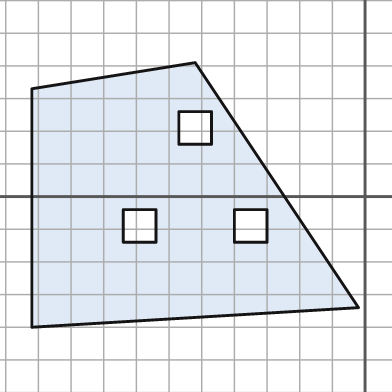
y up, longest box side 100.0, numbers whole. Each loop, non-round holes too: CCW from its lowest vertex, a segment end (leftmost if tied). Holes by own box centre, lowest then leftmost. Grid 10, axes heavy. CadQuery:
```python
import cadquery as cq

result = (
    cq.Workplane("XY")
    .moveTo(-102.0, -40.0)
    .lineTo(-2.0, -34.0)
    .lineTo(-52.0, 41.0)
    .lineTo(-102.0, 33.0)
    .close()
    .moveTo(-74.0, -14.0)
    .lineTo(-64.0, -14.0)
    .lineTo(-64.0, -4.0)
    .lineTo(-74.0, -4.0)
    .close()
    .moveTo(-40.0, -14.0)
    .lineTo(-30.0, -14.0)
    .lineTo(-30.0, -4.0)
    .lineTo(-40.0, -4.0)
    .close()
    .moveTo(-57.0, 16.0)
    .lineTo(-47.0, 16.0)
    .lineTo(-47.0, 26.0)
    .lineTo(-57.0, 26.0)
    .close()
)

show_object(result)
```